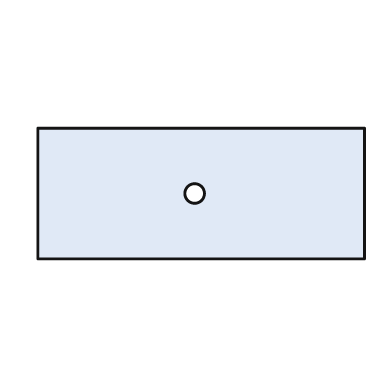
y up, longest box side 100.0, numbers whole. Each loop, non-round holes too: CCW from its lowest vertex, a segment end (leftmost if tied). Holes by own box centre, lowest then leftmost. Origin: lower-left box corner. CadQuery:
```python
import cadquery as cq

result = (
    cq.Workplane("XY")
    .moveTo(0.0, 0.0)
    .lineTo(100.0, 0.0)
    .lineTo(100.0, 40.0)
    .lineTo(0.0, 40.0)
    .close()
    .moveTo(48.0, 20.0)
    .circle(3.0)
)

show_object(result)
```